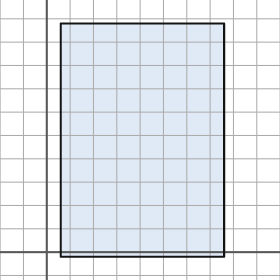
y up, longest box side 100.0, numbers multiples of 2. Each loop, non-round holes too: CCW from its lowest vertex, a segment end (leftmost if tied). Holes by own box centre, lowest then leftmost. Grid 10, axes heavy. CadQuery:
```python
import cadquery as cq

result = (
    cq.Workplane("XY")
    .moveTo(6.0, -2.0)
    .lineTo(76.0, -2.0)
    .lineTo(76.0, 98.0)
    .lineTo(6.0, 98.0)
    .close()
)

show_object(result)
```